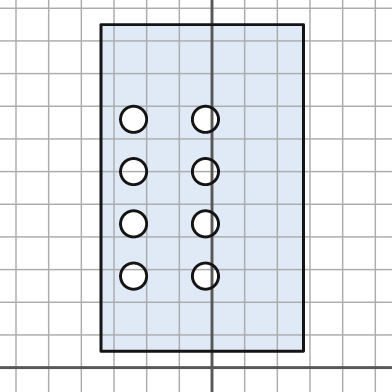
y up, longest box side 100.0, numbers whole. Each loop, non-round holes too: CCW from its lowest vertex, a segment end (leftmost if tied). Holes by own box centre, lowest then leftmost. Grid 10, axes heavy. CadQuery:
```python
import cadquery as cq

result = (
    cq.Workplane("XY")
    .moveTo(-34.0, 5.0)
    .lineTo(28.0, 5.0)
    .lineTo(28.0, 105.0)
    .lineTo(-34.0, 105.0)
    .close()
    .moveTo(-24.0, 28.0)
    .circle(4.0)
    .moveTo(-2.0, 28.0)
    .circle(4.0)
    .moveTo(-24.0, 44.0)
    .circle(4.0)
    .moveTo(-2.0, 44.0)
    .circle(4.0)
    .moveTo(-24.0, 60.0)
    .circle(4.0)
    .moveTo(-2.0, 60.0)
    .circle(4.0)
    .moveTo(-24.0, 76.0)
    .circle(4.0)
    .moveTo(-2.0, 76.0)
    .circle(4.0)
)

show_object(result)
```